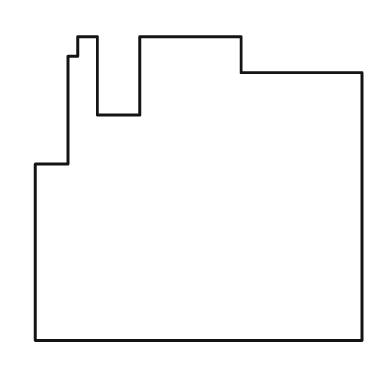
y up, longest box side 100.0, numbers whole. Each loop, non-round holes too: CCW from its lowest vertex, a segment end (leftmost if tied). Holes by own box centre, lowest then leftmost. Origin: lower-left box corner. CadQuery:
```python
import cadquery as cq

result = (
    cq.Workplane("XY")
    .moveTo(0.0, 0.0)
    .lineTo(100.0, 0.0)
    .lineTo(100.0, 82.0)
    .lineTo(63.0, 82.0)
    .lineTo(63.0, 93.0)
    .lineTo(32.0, 93.0)
    .lineTo(32.0, 69.0)
    .lineTo(19.0, 69.0)
    .lineTo(19.0, 93.0)
    .lineTo(13.0, 93.0)
    .lineTo(13.0, 87.0)
    .lineTo(10.0, 87.0)
    .lineTo(10.0, 54.0)
    .lineTo(0.0, 54.0)
    .close()
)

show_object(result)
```